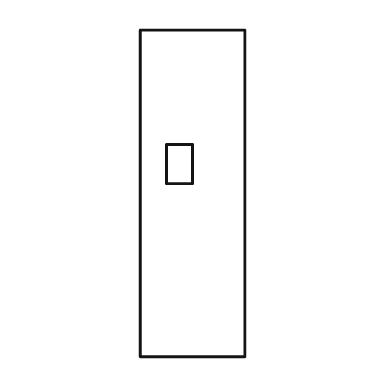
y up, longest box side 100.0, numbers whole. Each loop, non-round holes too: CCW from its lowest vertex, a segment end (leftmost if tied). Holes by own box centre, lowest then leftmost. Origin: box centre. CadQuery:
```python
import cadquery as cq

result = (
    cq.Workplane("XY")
    .moveTo(-16.0, -50.0)
    .lineTo(16.0, -50.0)
    .lineTo(16.0, 50.0)
    .lineTo(-16.0, 50.0)
    .close()
    .moveTo(-8.0, 3.0)
    .lineTo(0.0, 3.0)
    .lineTo(0.0, 15.0)
    .lineTo(-8.0, 15.0)
    .close()
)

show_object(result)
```